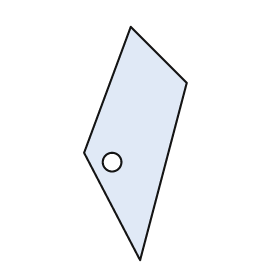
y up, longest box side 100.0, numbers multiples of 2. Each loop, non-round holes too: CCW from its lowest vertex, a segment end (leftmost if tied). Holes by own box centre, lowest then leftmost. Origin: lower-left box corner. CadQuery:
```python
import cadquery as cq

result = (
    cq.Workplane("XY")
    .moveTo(24.0, 0.0)
    .lineTo(44.0, 76.0)
    .lineTo(20.0, 100.0)
    .lineTo(0.0, 46.0)
    .close()
    .moveTo(12.0, 42.0)
    .circle(4.0)
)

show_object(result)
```